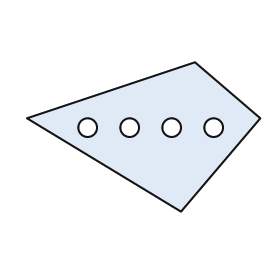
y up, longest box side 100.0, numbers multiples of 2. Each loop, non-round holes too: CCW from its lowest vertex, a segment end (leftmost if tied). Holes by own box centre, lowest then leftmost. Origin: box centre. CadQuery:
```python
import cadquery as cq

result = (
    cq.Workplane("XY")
    .moveTo(16.0, -32.0)
    .lineTo(50.0, 8.0)
    .lineTo(22.0, 32.0)
    .lineTo(-50.0, 8.0)
    .close()
    .moveTo(-24.0, 4.0)
    .circle(4.0)
    .moveTo(-6.0, 4.0)
    .circle(4.0)
    .moveTo(12.0, 4.0)
    .circle(4.0)
    .moveTo(30.0, 4.0)
    .circle(4.0)
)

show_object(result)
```